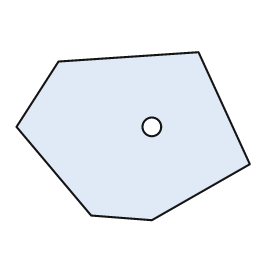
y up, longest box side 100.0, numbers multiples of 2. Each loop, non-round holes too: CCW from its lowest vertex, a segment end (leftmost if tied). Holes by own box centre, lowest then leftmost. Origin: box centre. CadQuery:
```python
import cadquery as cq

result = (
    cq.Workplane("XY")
    .moveTo(8.0, -36.0)
    .lineTo(50.0, -12.0)
    .lineTo(28.0, 36.0)
    .lineTo(-32.0, 32.0)
    .lineTo(-50.0, 4.0)
    .lineTo(-18.0, -34.0)
    .close()
    .moveTo(8.0, 4.0)
    .circle(4.0)
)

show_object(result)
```